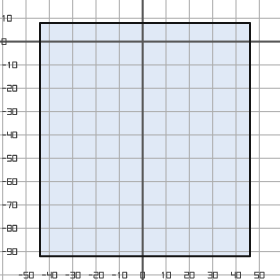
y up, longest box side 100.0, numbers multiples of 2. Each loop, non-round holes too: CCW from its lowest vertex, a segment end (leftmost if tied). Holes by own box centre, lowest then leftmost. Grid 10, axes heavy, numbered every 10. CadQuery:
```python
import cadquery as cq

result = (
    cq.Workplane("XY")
    .moveTo(-44.0, -92.0)
    .lineTo(46.0, -92.0)
    .lineTo(46.0, 8.0)
    .lineTo(-44.0, 8.0)
    .close()
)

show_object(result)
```